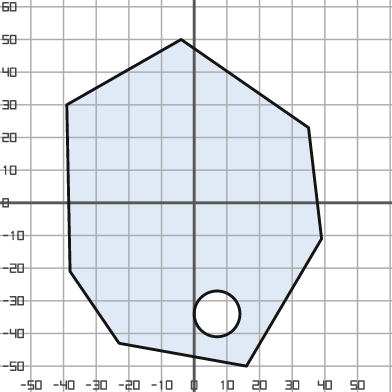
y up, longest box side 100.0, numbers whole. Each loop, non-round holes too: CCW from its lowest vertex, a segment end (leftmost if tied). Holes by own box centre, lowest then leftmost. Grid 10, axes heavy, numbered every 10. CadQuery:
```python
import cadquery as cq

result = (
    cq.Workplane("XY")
    .moveTo(16.0, -50.0)
    .lineTo(39.0, -11.0)
    .lineTo(35.0, 23.0)
    .lineTo(-4.0, 50.0)
    .lineTo(-39.0, 30.0)
    .lineTo(-38.0, -21.0)
    .lineTo(-23.0, -43.0)
    .close()
    .moveTo(7.0, -34.0)
    .circle(7.0)
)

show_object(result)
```